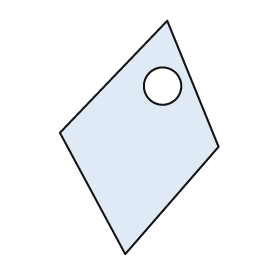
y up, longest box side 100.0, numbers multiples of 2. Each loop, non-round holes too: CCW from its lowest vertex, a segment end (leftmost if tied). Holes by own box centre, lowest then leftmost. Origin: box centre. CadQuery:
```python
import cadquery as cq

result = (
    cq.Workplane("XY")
    .moveTo(-6.0, -50.0)
    .lineTo(34.0, -4.0)
    .lineTo(12.0, 50.0)
    .lineTo(-34.0, 2.0)
    .close()
    .moveTo(10.0, 22.0)
    .circle(8.0)
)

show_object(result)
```